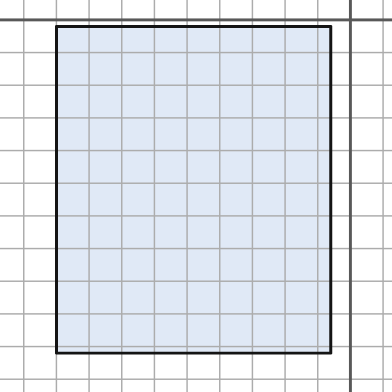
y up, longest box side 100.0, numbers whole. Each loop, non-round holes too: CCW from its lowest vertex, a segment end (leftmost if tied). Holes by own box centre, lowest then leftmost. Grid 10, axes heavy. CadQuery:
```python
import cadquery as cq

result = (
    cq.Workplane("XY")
    .moveTo(-90.0, -102.0)
    .lineTo(-6.0, -102.0)
    .lineTo(-6.0, -2.0)
    .lineTo(-90.0, -2.0)
    .close()
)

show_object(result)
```